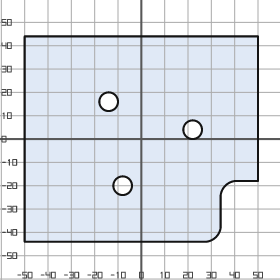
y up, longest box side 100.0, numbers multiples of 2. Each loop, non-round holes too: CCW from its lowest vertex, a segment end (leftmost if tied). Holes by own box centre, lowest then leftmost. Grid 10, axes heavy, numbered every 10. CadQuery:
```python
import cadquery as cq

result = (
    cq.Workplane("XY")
    .moveTo(-50.0, -44.0)
    .lineTo(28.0, -44.0)
    .threePointArc((32.0, -42.0), (34.0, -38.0))
    .lineTo(34.0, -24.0)
    .threePointArc((36.0, -20.0), (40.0, -18.0))
    .lineTo(50.0, -18.0)
    .lineTo(50.0, 44.0)
    .lineTo(-50.0, 44.0)
    .close()
    .moveTo(-8.0, -20.0)
    .circle(4.0)
    .moveTo(22.0, 4.0)
    .circle(4.0)
    .moveTo(-14.0, 16.0)
    .circle(4.0)
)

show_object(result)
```